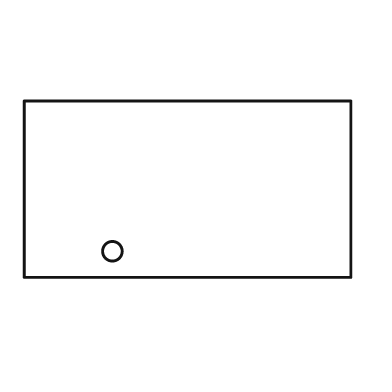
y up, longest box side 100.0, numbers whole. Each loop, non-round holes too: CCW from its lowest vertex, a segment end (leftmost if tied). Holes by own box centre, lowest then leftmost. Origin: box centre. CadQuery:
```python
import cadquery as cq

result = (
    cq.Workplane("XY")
    .moveTo(-50.0, -27.0)
    .lineTo(50.0, -27.0)
    .lineTo(50.0, 27.0)
    .lineTo(-50.0, 27.0)
    .close()
    .moveTo(-23.0, -19.0)
    .circle(3.0)
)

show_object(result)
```